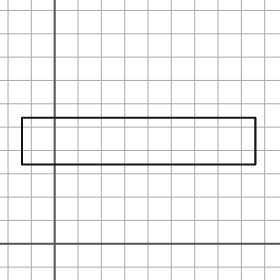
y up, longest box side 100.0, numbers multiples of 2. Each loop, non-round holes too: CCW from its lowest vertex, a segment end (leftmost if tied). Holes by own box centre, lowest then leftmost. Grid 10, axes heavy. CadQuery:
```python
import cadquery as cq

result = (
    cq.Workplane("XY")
    .moveTo(-14.0, 34.0)
    .lineTo(86.0, 34.0)
    .lineTo(86.0, 54.0)
    .lineTo(-14.0, 54.0)
    .close()
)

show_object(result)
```